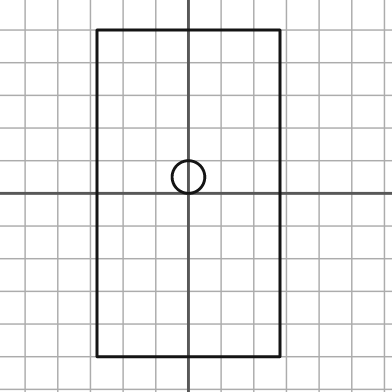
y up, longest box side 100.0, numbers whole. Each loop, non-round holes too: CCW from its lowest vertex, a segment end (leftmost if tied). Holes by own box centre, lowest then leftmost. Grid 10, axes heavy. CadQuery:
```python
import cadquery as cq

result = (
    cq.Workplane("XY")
    .moveTo(-28.0, -50.0)
    .lineTo(28.0, -50.0)
    .lineTo(28.0, 50.0)
    .lineTo(-28.0, 50.0)
    .close()
    .moveTo(0.0, 5.0)
    .circle(5.0)
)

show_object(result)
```